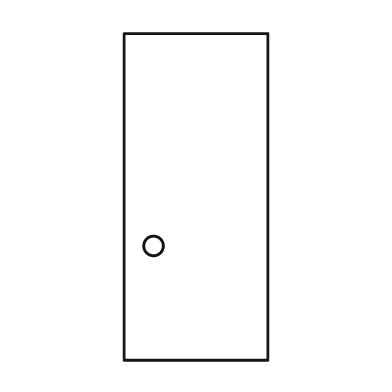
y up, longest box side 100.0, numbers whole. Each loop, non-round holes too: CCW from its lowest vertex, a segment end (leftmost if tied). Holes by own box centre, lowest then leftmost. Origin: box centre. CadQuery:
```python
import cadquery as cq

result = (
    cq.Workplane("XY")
    .moveTo(-22.0, -50.0)
    .lineTo(22.0, -50.0)
    .lineTo(22.0, 50.0)
    .lineTo(-22.0, 50.0)
    .close()
    .moveTo(-13.0, -15.0)
    .circle(3.0)
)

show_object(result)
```